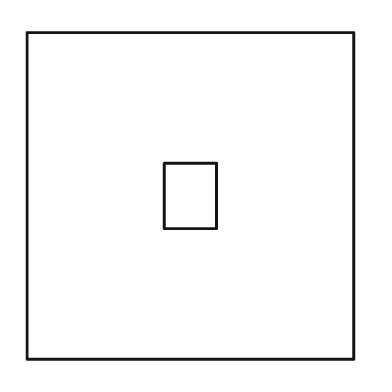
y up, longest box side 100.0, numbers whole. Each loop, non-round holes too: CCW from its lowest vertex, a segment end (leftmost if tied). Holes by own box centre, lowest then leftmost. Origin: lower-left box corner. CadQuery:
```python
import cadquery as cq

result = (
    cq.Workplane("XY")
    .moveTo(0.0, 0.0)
    .lineTo(100.0, 0.0)
    .lineTo(100.0, 100.0)
    .lineTo(0.0, 100.0)
    .close()
    .moveTo(42.0, 40.0)
    .lineTo(58.0, 40.0)
    .lineTo(58.0, 60.0)
    .lineTo(42.0, 60.0)
    .close()
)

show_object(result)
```